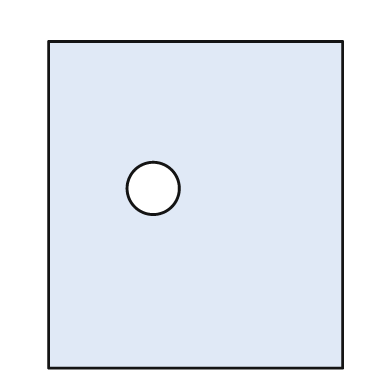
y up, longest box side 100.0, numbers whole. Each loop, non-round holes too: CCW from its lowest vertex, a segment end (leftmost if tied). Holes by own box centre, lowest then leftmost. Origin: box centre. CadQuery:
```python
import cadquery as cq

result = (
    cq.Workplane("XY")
    .moveTo(-45.0, -50.0)
    .lineTo(45.0, -50.0)
    .lineTo(45.0, 50.0)
    .lineTo(-45.0, 50.0)
    .close()
    .moveTo(-13.0, 5.0)
    .circle(8.0)
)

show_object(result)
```